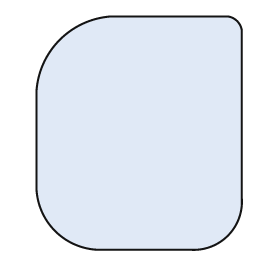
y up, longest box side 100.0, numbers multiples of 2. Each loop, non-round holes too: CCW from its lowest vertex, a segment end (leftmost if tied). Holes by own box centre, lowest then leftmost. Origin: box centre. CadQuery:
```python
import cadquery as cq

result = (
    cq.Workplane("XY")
    .moveTo(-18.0, -50.0)
    .lineTo(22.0, -50.0)
    .threePointArc((38.0, -44.0), (44.0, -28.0))
    .lineTo(44.0, 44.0)
    .threePointArc((42.0, 48.0), (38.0, 50.0))
    .lineTo(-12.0, 50.0)
    .threePointArc((-34.0, 40.0), (-44.0, 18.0))
    .lineTo(-44.0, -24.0)
    .threePointArc((-36.0, -42.0), (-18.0, -50.0))
    .close()
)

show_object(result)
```